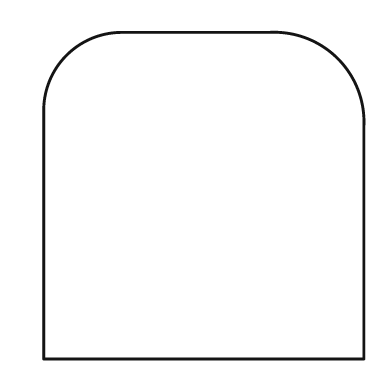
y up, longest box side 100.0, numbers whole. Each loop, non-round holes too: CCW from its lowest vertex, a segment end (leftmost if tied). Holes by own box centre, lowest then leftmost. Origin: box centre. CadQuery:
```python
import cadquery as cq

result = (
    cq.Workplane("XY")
    .moveTo(-49.0, -50.0)
    .lineTo(49.0, -50.0)
    .lineTo(49.0, 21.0)
    .threePointArc((41.0, 42.0), (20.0, 50.0))
    .lineTo(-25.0, 50.0)
    .threePointArc((-42.0, 43.0), (-49.0, 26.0))
    .close()
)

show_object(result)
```